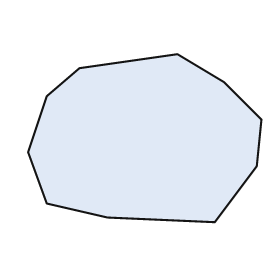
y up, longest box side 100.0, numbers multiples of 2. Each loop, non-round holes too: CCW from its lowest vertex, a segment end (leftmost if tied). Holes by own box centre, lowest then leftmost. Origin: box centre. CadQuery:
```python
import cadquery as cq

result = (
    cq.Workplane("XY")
    .moveTo(30.0, -36.0)
    .lineTo(48.0, -12.0)
    .lineTo(50.0, 8.0)
    .lineTo(34.0, 24.0)
    .lineTo(14.0, 36.0)
    .lineTo(-28.0, 30.0)
    .lineTo(-42.0, 18.0)
    .lineTo(-50.0, -6.0)
    .lineTo(-42.0, -28.0)
    .lineTo(-16.0, -34.0)
    .close()
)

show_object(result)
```